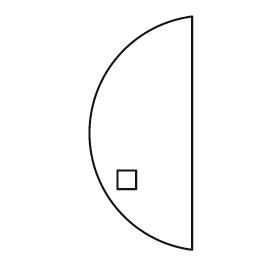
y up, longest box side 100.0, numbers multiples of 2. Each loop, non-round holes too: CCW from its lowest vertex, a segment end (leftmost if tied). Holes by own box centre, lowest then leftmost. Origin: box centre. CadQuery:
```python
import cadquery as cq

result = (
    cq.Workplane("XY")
    .moveTo(22.0, -50.0)
    .lineTo(22.0, 50.0)
    .threePointArc((-22.0, 0.0), (22.0, -50.0))
    .close()
    .moveTo(-10.0, -24.0)
    .lineTo(-2.0, -24.0)
    .lineTo(-2.0, -16.0)
    .lineTo(-10.0, -16.0)
    .close()
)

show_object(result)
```